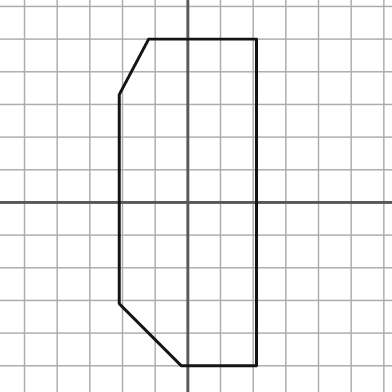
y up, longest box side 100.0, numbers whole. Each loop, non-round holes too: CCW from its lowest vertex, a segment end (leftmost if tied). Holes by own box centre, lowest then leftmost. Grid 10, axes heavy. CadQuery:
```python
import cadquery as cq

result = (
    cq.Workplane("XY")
    .moveTo(-2.0, -50.0)
    .lineTo(21.0, -50.0)
    .lineTo(21.0, 50.0)
    .lineTo(-12.0, 50.0)
    .lineTo(-21.0, 33.0)
    .lineTo(-21.0, -31.0)
    .close()
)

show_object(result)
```